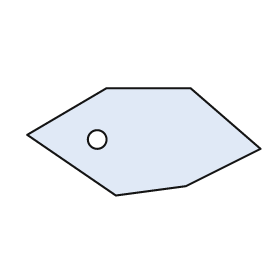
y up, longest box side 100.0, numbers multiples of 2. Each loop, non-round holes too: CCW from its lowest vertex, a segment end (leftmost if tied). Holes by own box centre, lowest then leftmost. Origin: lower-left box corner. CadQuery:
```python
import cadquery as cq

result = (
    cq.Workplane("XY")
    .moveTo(38.0, 0.0)
    .lineTo(68.0, 4.0)
    .lineTo(100.0, 20.0)
    .lineTo(70.0, 46.0)
    .lineTo(34.0, 46.0)
    .lineTo(0.0, 26.0)
    .close()
    .moveTo(30.0, 24.0)
    .circle(4.0)
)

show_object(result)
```